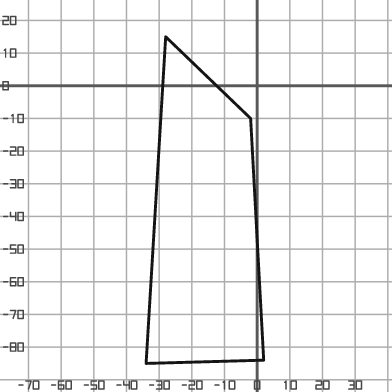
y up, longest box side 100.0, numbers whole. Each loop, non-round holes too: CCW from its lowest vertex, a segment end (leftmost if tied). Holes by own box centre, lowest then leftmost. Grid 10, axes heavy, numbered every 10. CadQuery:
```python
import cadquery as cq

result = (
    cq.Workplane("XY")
    .moveTo(-34.0, -85.0)
    .lineTo(2.0, -84.0)
    .lineTo(-2.0, -10.0)
    .lineTo(-28.0, 15.0)
    .close()
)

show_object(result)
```